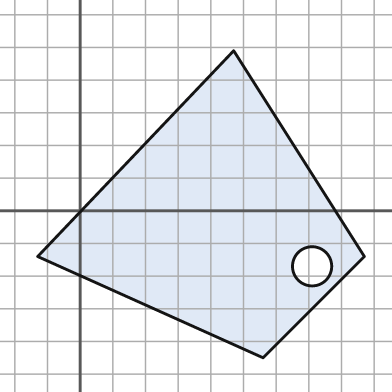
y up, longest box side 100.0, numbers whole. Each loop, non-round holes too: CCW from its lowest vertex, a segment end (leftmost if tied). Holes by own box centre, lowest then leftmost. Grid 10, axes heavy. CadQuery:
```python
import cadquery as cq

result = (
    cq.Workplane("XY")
    .moveTo(56.0, -45.0)
    .lineTo(87.0, -14.0)
    .lineTo(47.0, 49.0)
    .lineTo(-13.0, -14.0)
    .close()
    .moveTo(71.0, -17.0)
    .circle(6.0)
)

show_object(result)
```